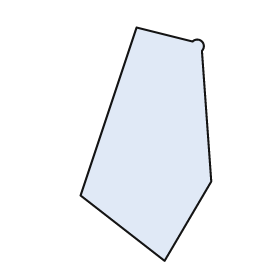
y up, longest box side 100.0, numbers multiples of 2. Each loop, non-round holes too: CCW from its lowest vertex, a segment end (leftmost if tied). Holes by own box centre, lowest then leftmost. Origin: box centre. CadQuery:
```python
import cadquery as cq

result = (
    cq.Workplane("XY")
    .moveTo(8.0, -50.0)
    .lineTo(28.0, -16.0)
    .lineTo(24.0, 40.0)
    .threePointArc((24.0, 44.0), (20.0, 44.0))
    .lineTo(-4.0, 50.0)
    .lineTo(-28.0, -22.0)
    .close()
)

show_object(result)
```